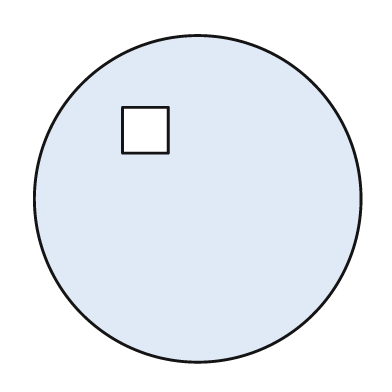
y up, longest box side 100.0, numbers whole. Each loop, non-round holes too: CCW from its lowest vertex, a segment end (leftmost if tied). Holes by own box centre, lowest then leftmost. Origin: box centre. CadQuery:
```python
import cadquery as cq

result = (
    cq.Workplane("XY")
    .moveTo(0.0, 0.0)
    .circle(50.0)
    .moveTo(-23.0, 14.0)
    .lineTo(-9.0, 14.0)
    .lineTo(-9.0, 28.0)
    .lineTo(-23.0, 28.0)
    .close()
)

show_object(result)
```